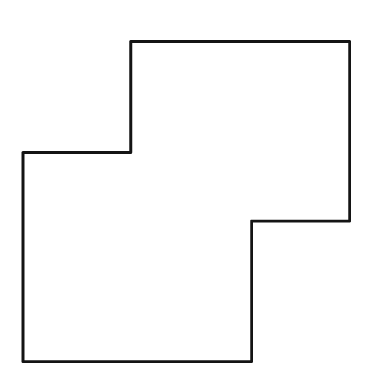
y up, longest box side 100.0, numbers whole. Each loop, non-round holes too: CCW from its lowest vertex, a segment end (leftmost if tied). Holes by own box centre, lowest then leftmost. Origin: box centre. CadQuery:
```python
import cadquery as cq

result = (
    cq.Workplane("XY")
    .moveTo(-50.0, -49.0)
    .lineTo(20.0, -49.0)
    .lineTo(20.0, -6.0)
    .lineTo(50.0, -6.0)
    .lineTo(50.0, 49.0)
    .lineTo(-17.0, 49.0)
    .lineTo(-17.0, 15.0)
    .lineTo(-50.0, 15.0)
    .close()
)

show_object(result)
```